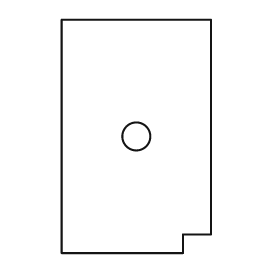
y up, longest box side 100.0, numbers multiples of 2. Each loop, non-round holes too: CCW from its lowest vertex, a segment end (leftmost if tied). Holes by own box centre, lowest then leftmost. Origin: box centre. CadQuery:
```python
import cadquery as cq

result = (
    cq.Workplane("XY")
    .moveTo(-32.0, -50.0)
    .lineTo(20.0, -50.0)
    .lineTo(20.0, -42.0)
    .lineTo(32.0, -42.0)
    .lineTo(32.0, 50.0)
    .lineTo(-32.0, 50.0)
    .close()
    .moveTo(0.0, 0.0)
    .circle(6.0)
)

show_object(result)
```